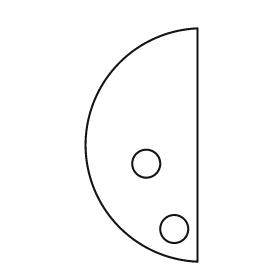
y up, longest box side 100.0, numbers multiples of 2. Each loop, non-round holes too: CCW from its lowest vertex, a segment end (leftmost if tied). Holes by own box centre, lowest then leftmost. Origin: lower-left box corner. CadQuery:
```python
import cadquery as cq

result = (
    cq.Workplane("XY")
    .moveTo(48.0, 0.0)
    .lineTo(48.0, 100.0)
    .threePointArc((0.0, 50.0), (48.0, 0.0))
    .close()
    .moveTo(38.0, 14.0)
    .circle(6.0)
    .moveTo(26.0, 42.0)
    .circle(6.0)
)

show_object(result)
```